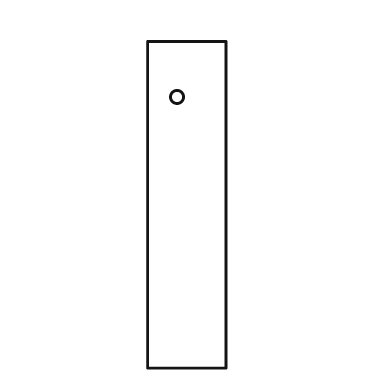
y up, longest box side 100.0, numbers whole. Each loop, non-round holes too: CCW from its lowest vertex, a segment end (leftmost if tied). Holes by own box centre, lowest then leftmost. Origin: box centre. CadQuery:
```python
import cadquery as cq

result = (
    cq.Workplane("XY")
    .moveTo(-12.0, -50.0)
    .lineTo(12.0, -50.0)
    .lineTo(12.0, 50.0)
    .lineTo(-12.0, 50.0)
    .close()
    .moveTo(-3.0, 33.0)
    .circle(2.0)
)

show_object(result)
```